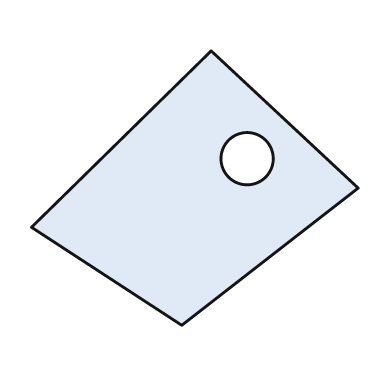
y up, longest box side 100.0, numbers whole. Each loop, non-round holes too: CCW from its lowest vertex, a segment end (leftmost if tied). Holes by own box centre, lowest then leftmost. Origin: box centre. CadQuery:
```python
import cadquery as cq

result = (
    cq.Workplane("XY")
    .moveTo(-4.0, -42.0)
    .lineTo(50.0, 0.0)
    .lineTo(5.0, 42.0)
    .lineTo(-50.0, -12.0)
    .close()
    .moveTo(16.0, 9.0)
    .circle(8.0)
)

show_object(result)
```